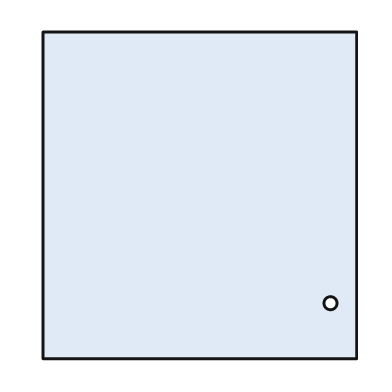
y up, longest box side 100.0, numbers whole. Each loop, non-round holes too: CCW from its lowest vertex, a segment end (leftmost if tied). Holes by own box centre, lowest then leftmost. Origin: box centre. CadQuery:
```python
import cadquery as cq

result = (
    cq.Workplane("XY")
    .moveTo(-48.0, -50.0)
    .lineTo(48.0, -50.0)
    .lineTo(48.0, 50.0)
    .lineTo(-48.0, 50.0)
    .close()
    .moveTo(40.0, -33.0)
    .circle(2.0)
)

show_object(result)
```